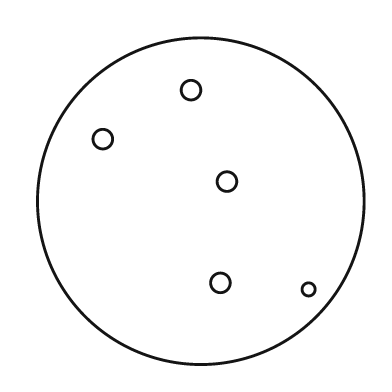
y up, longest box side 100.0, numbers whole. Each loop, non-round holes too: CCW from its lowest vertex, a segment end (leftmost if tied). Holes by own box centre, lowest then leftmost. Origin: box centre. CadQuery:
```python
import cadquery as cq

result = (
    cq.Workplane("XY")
    .moveTo(0.0, 0.0)
    .circle(50.0)
    .moveTo(33.0, -27.0)
    .circle(2.0)
    .moveTo(6.0, -25.0)
    .circle(3.0)
    .moveTo(8.0, 6.0)
    .circle(3.0)
    .moveTo(-30.0, 19.0)
    .circle(3.0)
    .moveTo(-3.0, 34.0)
    .circle(3.0)
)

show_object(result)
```